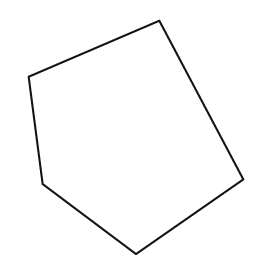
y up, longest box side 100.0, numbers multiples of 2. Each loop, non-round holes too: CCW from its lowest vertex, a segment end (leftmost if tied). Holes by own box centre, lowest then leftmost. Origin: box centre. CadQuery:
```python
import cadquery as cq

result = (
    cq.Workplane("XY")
    .moveTo(0.0, -50.0)
    .lineTo(46.0, -18.0)
    .lineTo(10.0, 50.0)
    .lineTo(-46.0, 26.0)
    .lineTo(-40.0, -20.0)
    .close()
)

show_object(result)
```